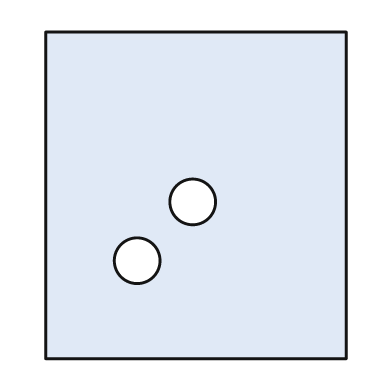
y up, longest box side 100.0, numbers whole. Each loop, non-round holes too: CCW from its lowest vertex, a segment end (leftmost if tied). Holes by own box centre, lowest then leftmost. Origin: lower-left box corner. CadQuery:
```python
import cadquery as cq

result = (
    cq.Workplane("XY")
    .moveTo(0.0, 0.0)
    .lineTo(92.0, 0.0)
    .lineTo(92.0, 100.0)
    .lineTo(0.0, 100.0)
    .close()
    .moveTo(28.0, 30.0)
    .circle(7.0)
    .moveTo(45.0, 48.0)
    .circle(7.0)
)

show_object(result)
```